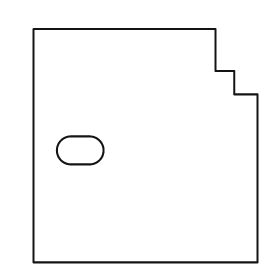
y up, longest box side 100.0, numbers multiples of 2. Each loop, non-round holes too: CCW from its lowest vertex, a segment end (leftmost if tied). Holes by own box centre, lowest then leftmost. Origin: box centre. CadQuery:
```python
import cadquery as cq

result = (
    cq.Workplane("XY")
    .moveTo(-48.0, -50.0)
    .lineTo(48.0, -50.0)
    .lineTo(48.0, 22.0)
    .lineTo(38.0, 22.0)
    .lineTo(38.0, 32.0)
    .lineTo(30.0, 32.0)
    .lineTo(30.0, 50.0)
    .lineTo(-48.0, 50.0)
    .close()
    .moveTo(-32.0, -8.0)
    .lineTo(-24.0, -8.0)
    .threePointArc((-18.0, -2.0), (-24.0, 4.0))
    .lineTo(-32.0, 4.0)
    .threePointArc((-38.0, -2.0), (-32.0, -8.0))
    .close()
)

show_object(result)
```